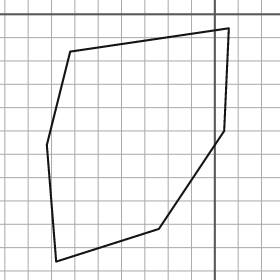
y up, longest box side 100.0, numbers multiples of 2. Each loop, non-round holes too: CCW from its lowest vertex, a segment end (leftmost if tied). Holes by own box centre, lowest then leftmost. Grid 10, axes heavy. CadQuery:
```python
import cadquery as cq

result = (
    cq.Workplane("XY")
    .moveTo(-68.0, -106.0)
    .lineTo(-24.0, -92.0)
    .lineTo(4.0, -50.0)
    .lineTo(6.0, -6.0)
    .lineTo(-62.0, -16.0)
    .lineTo(-72.0, -56.0)
    .close()
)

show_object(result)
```